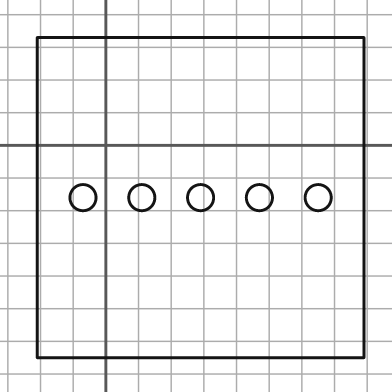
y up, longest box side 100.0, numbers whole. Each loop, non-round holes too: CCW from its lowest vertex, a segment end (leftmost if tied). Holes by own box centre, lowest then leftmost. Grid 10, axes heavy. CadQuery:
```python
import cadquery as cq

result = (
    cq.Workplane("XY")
    .moveTo(-21.0, -65.0)
    .lineTo(79.0, -65.0)
    .lineTo(79.0, 33.0)
    .lineTo(-21.0, 33.0)
    .close()
    .moveTo(-7.0, -16.0)
    .circle(4.0)
    .moveTo(11.0, -16.0)
    .circle(4.0)
    .moveTo(29.0, -16.0)
    .circle(4.0)
    .moveTo(47.0, -16.0)
    .circle(4.0)
    .moveTo(65.0, -16.0)
    .circle(4.0)
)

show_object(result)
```